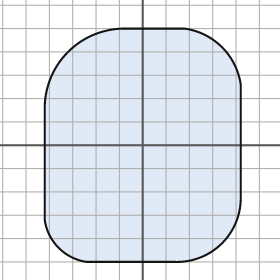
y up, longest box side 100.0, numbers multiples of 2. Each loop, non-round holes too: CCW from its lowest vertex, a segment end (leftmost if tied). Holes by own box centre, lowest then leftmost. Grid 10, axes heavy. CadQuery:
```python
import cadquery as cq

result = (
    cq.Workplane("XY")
    .moveTo(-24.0, -50.0)
    .lineTo(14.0, -50.0)
    .threePointArc((34.0, -42.0), (42.0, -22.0))
    .lineTo(42.0, 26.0)
    .threePointArc((34.0, 42.0), (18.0, 50.0))
    .lineTo(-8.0, 50.0)
    .threePointArc((-32.0, 40.0), (-42.0, 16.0))
    .lineTo(-42.0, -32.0)
    .threePointArc((-36.0, -44.0), (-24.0, -50.0))
    .close()
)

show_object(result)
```